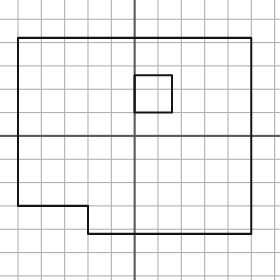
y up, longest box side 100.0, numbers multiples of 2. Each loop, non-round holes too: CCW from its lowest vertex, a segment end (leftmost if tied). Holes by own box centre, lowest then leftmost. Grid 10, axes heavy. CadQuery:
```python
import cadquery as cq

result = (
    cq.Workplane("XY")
    .moveTo(-20.0, -42.0)
    .lineTo(50.0, -42.0)
    .lineTo(50.0, 42.0)
    .lineTo(-50.0, 42.0)
    .lineTo(-50.0, -30.0)
    .lineTo(-20.0, -30.0)
    .close()
    .moveTo(0.0, 10.0)
    .lineTo(16.0, 10.0)
    .lineTo(16.0, 26.0)
    .lineTo(0.0, 26.0)
    .close()
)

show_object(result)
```